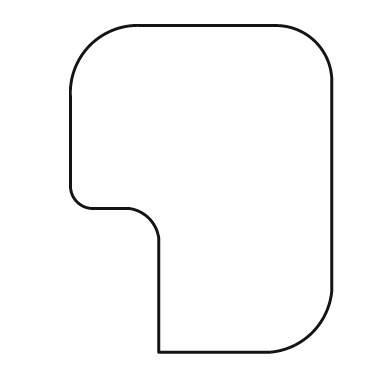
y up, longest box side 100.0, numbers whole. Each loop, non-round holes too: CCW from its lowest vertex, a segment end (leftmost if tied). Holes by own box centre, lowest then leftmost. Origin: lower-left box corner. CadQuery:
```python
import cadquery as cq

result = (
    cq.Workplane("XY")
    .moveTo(27.0, 0.0)
    .lineTo(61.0, 0.0)
    .threePointArc((74.0, 6.0), (80.0, 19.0))
    .lineTo(80.0, 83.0)
    .threePointArc((75.0, 95.0), (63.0, 100.0))
    .lineTo(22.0, 100.0)
    .threePointArc((6.0, 94.0), (0.0, 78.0))
    .lineTo(0.0, 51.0)
    .threePointArc((2.0, 46.0), (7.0, 44.0))
    .lineTo(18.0, 44.0)
    .threePointArc((24.0, 41.0), (27.0, 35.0))
    .close()
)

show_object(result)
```